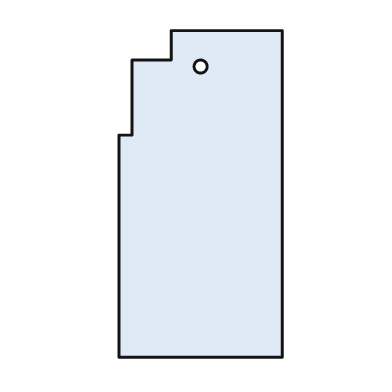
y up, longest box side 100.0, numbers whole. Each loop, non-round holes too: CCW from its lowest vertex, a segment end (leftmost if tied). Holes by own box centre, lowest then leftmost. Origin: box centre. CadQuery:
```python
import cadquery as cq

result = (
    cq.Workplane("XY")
    .moveTo(-25.0, -50.0)
    .lineTo(25.0, -50.0)
    .lineTo(25.0, 50.0)
    .lineTo(-9.0, 50.0)
    .lineTo(-9.0, 41.0)
    .lineTo(-21.0, 41.0)
    .lineTo(-21.0, 18.0)
    .lineTo(-25.0, 18.0)
    .close()
    .moveTo(0.0, 39.0)
    .circle(2.0)
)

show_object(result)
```